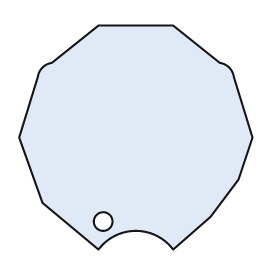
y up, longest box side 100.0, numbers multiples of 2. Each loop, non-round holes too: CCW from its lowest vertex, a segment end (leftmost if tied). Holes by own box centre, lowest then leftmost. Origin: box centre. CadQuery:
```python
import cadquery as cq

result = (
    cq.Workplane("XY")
    .moveTo(-16.0, -48.0)
    .threePointArc((0.0, -40.0), (16.0, -48.0))
    .lineTo(32.0, -34.0)
    .lineTo(44.0, -18.0)
    .lineTo(50.0, 0.0)
    .lineTo(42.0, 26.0)
    .threePointArc((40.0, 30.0), (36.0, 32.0))
    .lineTo(16.0, 48.0)
    .lineTo(-16.0, 48.0)
    .lineTo(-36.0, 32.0)
    .threePointArc((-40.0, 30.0), (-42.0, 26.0))
    .lineTo(-50.0, 0.0)
    .lineTo(-40.0, -28.0)
    .close()
    .moveTo(-14.0, -36.0)
    .circle(4.0)
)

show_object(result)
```